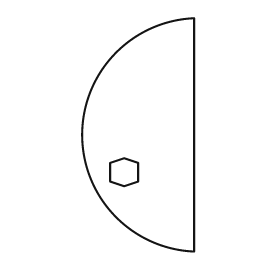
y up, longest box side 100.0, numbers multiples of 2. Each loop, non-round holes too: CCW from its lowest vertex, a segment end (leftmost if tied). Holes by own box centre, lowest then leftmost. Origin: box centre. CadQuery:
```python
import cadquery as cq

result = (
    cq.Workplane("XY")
    .moveTo(24.0, -50.0)
    .lineTo(24.0, 50.0)
    .threePointArc((-24.0, 0.0), (24.0, -50.0))
    .close()
    .moveTo(-6.0, -22.0)
    .lineTo(0.0, -20.0)
    .lineTo(0.0, -12.0)
    .lineTo(-6.0, -10.0)
    .lineTo(-12.0, -12.0)
    .lineTo(-12.0, -20.0)
    .close()
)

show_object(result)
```